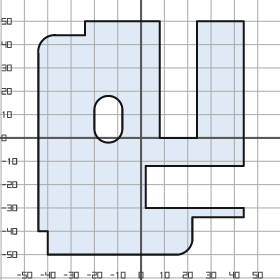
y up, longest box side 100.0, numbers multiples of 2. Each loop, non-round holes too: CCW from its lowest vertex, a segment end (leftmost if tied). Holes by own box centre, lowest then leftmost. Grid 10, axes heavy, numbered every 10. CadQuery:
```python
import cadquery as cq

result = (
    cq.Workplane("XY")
    .moveTo(-40.0, -50.0)
    .lineTo(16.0, -50.0)
    .threePointArc((20.0, -48.0), (22.0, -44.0))
    .lineTo(22.0, -34.0)
    .lineTo(44.0, -34.0)
    .lineTo(44.0, -30.0)
    .lineTo(2.0, -30.0)
    .lineTo(2.0, -12.0)
    .lineTo(44.0, -12.0)
    .lineTo(44.0, 50.0)
    .lineTo(24.0, 50.0)
    .lineTo(24.0, 0.0)
    .lineTo(8.0, 0.0)
    .lineTo(8.0, 50.0)
    .lineTo(-24.0, 50.0)
    .lineTo(-24.0, 44.0)
    .lineTo(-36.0, 44.0)
    .threePointArc((-42.0, 42.0), (-44.0, 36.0))
    .lineTo(-44.0, -40.0)
    .lineTo(-40.0, -40.0)
    .close()
    .moveTo(-20.0, 4.0)
    .threePointArc((-14.0, -2.0), (-8.0, 4.0))
    .lineTo(-8.0, 12.0)
    .threePointArc((-14.0, 18.0), (-20.0, 12.0))
    .close()
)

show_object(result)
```